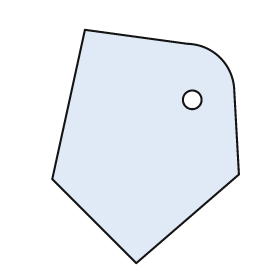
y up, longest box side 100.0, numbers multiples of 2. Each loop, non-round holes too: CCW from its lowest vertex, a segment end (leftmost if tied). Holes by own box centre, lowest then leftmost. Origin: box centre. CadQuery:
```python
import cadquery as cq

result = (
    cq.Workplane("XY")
    .moveTo(-4.0, -50.0)
    .lineTo(40.0, -12.0)
    .lineTo(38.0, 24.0)
    .threePointArc((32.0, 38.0), (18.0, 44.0))
    .lineTo(-26.0, 50.0)
    .lineTo(-40.0, -14.0)
    .close()
    .moveTo(20.0, 20.0)
    .circle(4.0)
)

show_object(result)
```